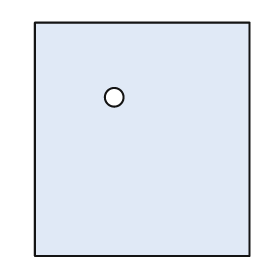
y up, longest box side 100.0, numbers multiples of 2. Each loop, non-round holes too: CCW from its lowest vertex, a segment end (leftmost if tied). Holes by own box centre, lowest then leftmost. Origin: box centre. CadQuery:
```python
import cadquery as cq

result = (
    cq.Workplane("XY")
    .moveTo(-46.0, -50.0)
    .lineTo(46.0, -50.0)
    .lineTo(46.0, 50.0)
    .lineTo(-46.0, 50.0)
    .close()
    .moveTo(-12.0, 18.0)
    .circle(4.0)
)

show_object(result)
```